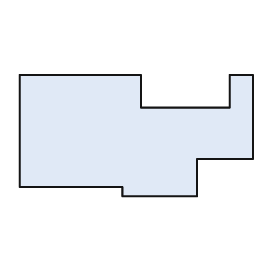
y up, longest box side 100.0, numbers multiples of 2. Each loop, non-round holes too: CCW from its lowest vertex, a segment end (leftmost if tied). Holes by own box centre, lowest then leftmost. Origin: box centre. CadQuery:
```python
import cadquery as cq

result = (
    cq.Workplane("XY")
    .moveTo(-6.0, -26.0)
    .lineTo(26.0, -26.0)
    .lineTo(26.0, -10.0)
    .lineTo(50.0, -10.0)
    .lineTo(50.0, 26.0)
    .lineTo(40.0, 26.0)
    .lineTo(40.0, 12.0)
    .lineTo(2.0, 12.0)
    .lineTo(2.0, 26.0)
    .lineTo(-50.0, 26.0)
    .lineTo(-50.0, -22.0)
    .lineTo(-6.0, -22.0)
    .close()
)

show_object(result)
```